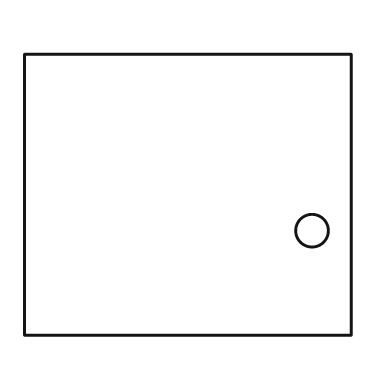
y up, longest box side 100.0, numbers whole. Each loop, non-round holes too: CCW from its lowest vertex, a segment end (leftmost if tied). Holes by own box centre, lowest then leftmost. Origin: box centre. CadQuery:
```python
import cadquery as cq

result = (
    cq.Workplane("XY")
    .moveTo(-50.0, -43.0)
    .lineTo(50.0, -43.0)
    .lineTo(50.0, 43.0)
    .lineTo(-50.0, 43.0)
    .close()
    .moveTo(38.0, -11.0)
    .circle(5.0)
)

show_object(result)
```